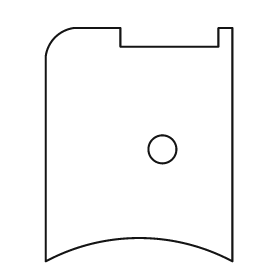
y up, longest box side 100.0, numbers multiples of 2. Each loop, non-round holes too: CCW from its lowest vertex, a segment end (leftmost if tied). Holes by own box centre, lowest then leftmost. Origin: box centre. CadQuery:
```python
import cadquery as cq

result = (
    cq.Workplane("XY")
    .moveTo(-40.0, -50.0)
    .threePointArc((0.0, -40.0), (40.0, -50.0))
    .lineTo(40.0, 50.0)
    .lineTo(34.0, 50.0)
    .lineTo(34.0, 42.0)
    .lineTo(-8.0, 42.0)
    .lineTo(-8.0, 50.0)
    .lineTo(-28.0, 50.0)
    .threePointArc((-36.0, 46.0), (-40.0, 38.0))
    .close()
    .moveTo(10.0, -2.0)
    .circle(6.0)
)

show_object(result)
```